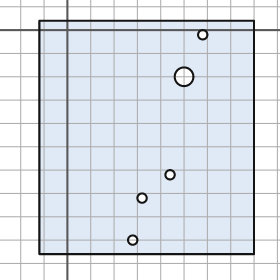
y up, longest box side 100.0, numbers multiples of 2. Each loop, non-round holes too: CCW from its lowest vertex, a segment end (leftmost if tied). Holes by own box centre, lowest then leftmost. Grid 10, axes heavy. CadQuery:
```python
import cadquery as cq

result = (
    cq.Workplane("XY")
    .moveTo(-12.0, -96.0)
    .lineTo(80.0, -96.0)
    .lineTo(80.0, 4.0)
    .lineTo(-12.0, 4.0)
    .close()
    .moveTo(28.0, -90.0)
    .circle(2.0)
    .moveTo(32.0, -72.0)
    .circle(2.0)
    .moveTo(44.0, -62.0)
    .circle(2.0)
    .moveTo(50.0, -20.0)
    .circle(4.0)
    .moveTo(58.0, -2.0)
    .circle(2.0)
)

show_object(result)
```